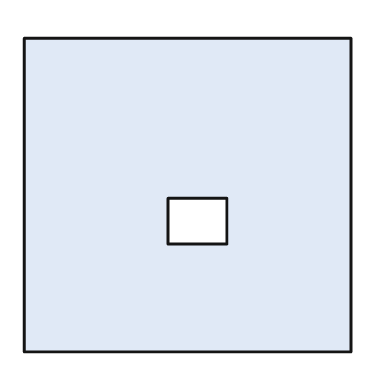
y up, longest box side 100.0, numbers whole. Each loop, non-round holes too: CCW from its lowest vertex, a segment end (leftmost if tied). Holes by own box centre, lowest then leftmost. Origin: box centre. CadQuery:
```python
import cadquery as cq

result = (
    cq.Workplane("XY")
    .moveTo(-50.0, -48.0)
    .lineTo(50.0, -48.0)
    .lineTo(50.0, 48.0)
    .lineTo(-50.0, 48.0)
    .close()
    .moveTo(-6.0, -15.0)
    .lineTo(12.0, -15.0)
    .lineTo(12.0, -1.0)
    .lineTo(-6.0, -1.0)
    .close()
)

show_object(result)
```